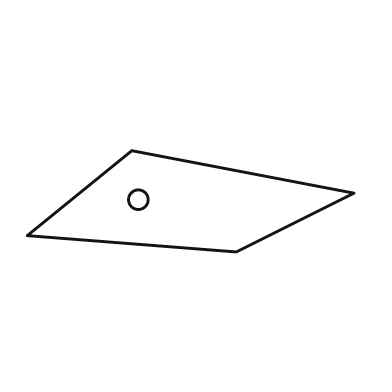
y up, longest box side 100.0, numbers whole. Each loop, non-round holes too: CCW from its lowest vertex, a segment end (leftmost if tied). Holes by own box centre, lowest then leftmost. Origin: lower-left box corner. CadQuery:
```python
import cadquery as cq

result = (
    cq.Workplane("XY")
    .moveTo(64.0, 0.0)
    .lineTo(100.0, 18.0)
    .lineTo(32.0, 31.0)
    .lineTo(0.0, 5.0)
    .close()
    .moveTo(34.0, 16.0)
    .circle(3.0)
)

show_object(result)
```